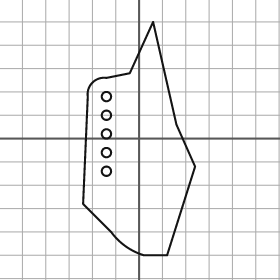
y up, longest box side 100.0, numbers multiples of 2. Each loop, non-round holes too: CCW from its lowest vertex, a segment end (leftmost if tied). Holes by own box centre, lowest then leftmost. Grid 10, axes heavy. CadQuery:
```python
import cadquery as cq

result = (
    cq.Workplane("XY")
    .moveTo(2.0, -50.0)
    .lineTo(12.0, -50.0)
    .lineTo(24.0, -12.0)
    .lineTo(16.0, 6.0)
    .lineTo(6.0, 50.0)
    .lineTo(-4.0, 28.0)
    .lineTo(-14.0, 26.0)
    .threePointArc((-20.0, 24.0), (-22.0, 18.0))
    .lineTo(-24.0, -28.0)
    .lineTo(-12.0, -40.0)
    .threePointArc((-6.0, -46.0), (2.0, -50.0))
    .close()
    .moveTo(-14.0, -14.0)
    .circle(2.0)
    .moveTo(-14.0, -6.0)
    .circle(2.0)
    .moveTo(-14.0, 2.0)
    .circle(2.0)
    .moveTo(-14.0, 10.0)
    .circle(2.0)
    .moveTo(-14.0, 18.0)
    .circle(2.0)
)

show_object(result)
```